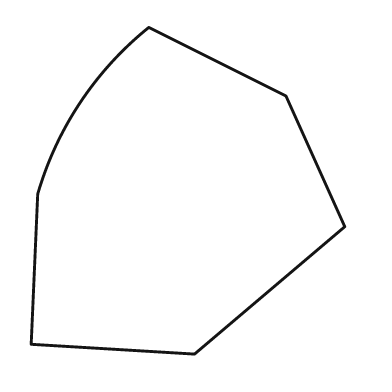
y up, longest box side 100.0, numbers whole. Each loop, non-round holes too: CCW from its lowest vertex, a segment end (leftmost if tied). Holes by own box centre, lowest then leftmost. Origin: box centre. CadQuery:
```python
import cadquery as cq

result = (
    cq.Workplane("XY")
    .moveTo(2.0, -50.0)
    .lineTo(48.0, -11.0)
    .lineTo(30.0, 29.0)
    .lineTo(-12.0, 50.0)
    .threePointArc((-33.0, 27.0), (-46.0, -1.0))
    .lineTo(-48.0, -47.0)
    .close()
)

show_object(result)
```